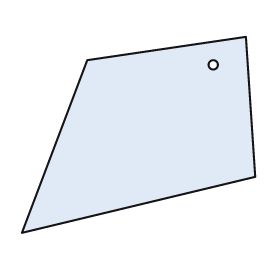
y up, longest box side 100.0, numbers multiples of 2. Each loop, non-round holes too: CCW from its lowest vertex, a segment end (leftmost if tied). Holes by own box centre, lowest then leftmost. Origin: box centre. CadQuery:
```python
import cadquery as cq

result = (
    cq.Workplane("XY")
    .moveTo(-50.0, -42.0)
    .lineTo(50.0, -18.0)
    .lineTo(46.0, 42.0)
    .lineTo(-22.0, 32.0)
    .close()
    .moveTo(32.0, 30.0)
    .circle(2.0)
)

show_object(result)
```